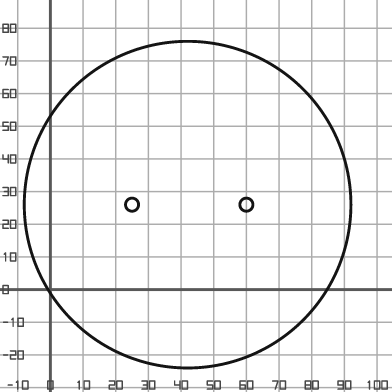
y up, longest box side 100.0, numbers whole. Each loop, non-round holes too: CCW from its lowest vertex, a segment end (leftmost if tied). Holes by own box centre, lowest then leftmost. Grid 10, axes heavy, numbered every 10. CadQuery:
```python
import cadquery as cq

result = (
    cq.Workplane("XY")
    .moveTo(42.0, 26.0)
    .circle(50.0)
    .moveTo(25.0, 26.0)
    .circle(2.0)
    .moveTo(60.0, 26.0)
    .circle(2.0)
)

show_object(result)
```